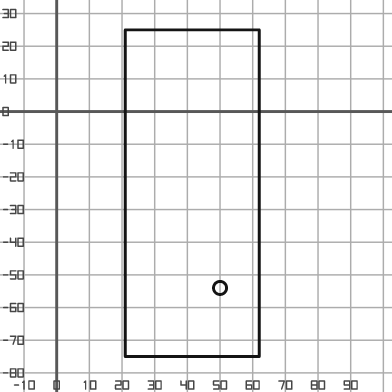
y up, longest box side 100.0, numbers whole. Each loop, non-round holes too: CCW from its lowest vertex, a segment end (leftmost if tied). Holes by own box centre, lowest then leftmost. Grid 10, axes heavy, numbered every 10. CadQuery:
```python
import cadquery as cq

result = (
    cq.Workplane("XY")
    .moveTo(21.0, -75.0)
    .lineTo(62.0, -75.0)
    .lineTo(62.0, 25.0)
    .lineTo(21.0, 25.0)
    .close()
    .moveTo(50.0, -54.0)
    .circle(2.0)
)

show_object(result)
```